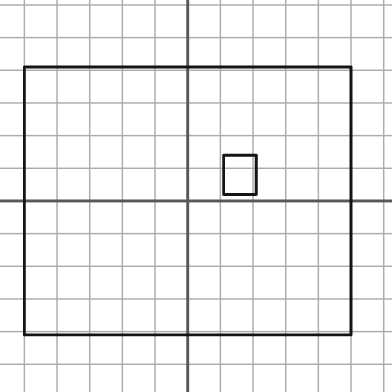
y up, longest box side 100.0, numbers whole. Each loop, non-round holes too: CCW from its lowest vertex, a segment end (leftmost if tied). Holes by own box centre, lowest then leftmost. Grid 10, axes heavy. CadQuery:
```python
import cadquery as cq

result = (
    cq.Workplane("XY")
    .moveTo(-50.0, -41.0)
    .lineTo(50.0, -41.0)
    .lineTo(50.0, 41.0)
    .lineTo(-50.0, 41.0)
    .close()
    .moveTo(11.0, 2.0)
    .lineTo(21.0, 2.0)
    .lineTo(21.0, 14.0)
    .lineTo(11.0, 14.0)
    .close()
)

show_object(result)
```